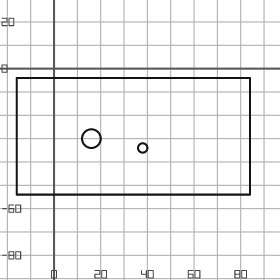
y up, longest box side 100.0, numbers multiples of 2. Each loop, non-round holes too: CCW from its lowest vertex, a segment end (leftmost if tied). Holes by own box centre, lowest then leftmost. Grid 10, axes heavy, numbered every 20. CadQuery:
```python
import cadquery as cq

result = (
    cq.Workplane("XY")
    .moveTo(-16.0, -54.0)
    .lineTo(84.0, -54.0)
    .lineTo(84.0, -4.0)
    .lineTo(-16.0, -4.0)
    .close()
    .moveTo(38.0, -34.0)
    .circle(2.0)
    .moveTo(16.0, -30.0)
    .circle(4.0)
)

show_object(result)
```